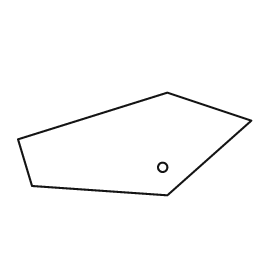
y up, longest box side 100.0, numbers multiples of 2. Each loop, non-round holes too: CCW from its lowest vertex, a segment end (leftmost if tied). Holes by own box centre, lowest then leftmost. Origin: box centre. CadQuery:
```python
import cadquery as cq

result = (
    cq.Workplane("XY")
    .moveTo(14.0, -22.0)
    .lineTo(50.0, 10.0)
    .lineTo(14.0, 22.0)
    .lineTo(-50.0, 2.0)
    .lineTo(-44.0, -18.0)
    .close()
    .moveTo(12.0, -10.0)
    .circle(2.0)
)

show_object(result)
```